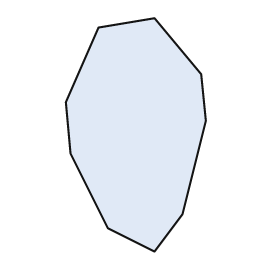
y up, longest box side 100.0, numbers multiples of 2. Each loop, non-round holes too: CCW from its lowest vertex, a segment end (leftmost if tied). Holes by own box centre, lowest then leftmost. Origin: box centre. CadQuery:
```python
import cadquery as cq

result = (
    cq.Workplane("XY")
    .moveTo(8.0, -50.0)
    .lineTo(20.0, -34.0)
    .lineTo(30.0, 6.0)
    .lineTo(28.0, 26.0)
    .lineTo(8.0, 50.0)
    .lineTo(-16.0, 46.0)
    .lineTo(-30.0, 14.0)
    .lineTo(-28.0, -8.0)
    .lineTo(-12.0, -40.0)
    .close()
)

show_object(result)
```